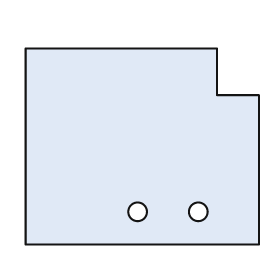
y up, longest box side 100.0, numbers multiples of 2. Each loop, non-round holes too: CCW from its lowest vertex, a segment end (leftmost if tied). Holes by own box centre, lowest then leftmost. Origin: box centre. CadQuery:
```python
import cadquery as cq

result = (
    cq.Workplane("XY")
    .moveTo(-50.0, -42.0)
    .lineTo(50.0, -42.0)
    .lineTo(50.0, 22.0)
    .lineTo(32.0, 22.0)
    .lineTo(32.0, 42.0)
    .lineTo(-50.0, 42.0)
    .close()
    .moveTo(-2.0, -28.0)
    .circle(4.0)
    .moveTo(24.0, -28.0)
    .circle(4.0)
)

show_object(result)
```